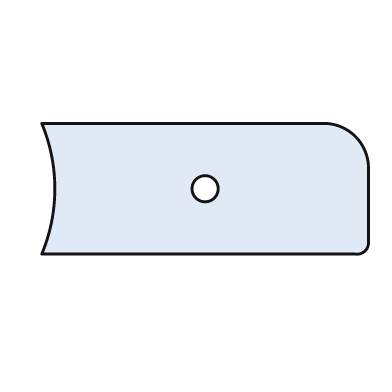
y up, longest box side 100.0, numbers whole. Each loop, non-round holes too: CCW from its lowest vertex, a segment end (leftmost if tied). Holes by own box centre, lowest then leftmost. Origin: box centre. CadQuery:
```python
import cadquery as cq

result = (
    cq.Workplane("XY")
    .moveTo(-50.0, -20.0)
    .lineTo(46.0, -20.0)
    .threePointArc((49.0, -19.0), (50.0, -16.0))
    .lineTo(50.0, 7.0)
    .threePointArc((46.0, 16.0), (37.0, 20.0))
    .lineTo(-50.0, 20.0)
    .threePointArc((-46.0, 0.0), (-50.0, -20.0))
    .close()
    .moveTo(0.0, 0.0)
    .circle(4.0)
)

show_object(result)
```